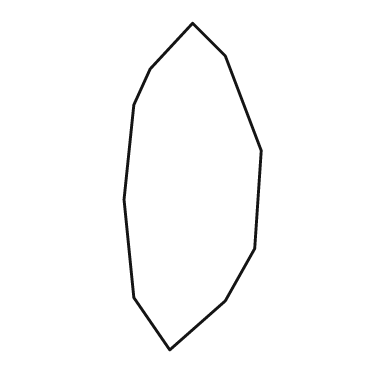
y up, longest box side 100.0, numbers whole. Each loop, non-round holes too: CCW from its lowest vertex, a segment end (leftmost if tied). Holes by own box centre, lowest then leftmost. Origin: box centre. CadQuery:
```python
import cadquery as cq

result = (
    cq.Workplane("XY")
    .moveTo(-7.0, -50.0)
    .lineTo(10.0, -35.0)
    .lineTo(19.0, -19.0)
    .lineTo(21.0, 11.0)
    .lineTo(10.0, 40.0)
    .lineTo(0.0, 50.0)
    .lineTo(-13.0, 36.0)
    .lineTo(-18.0, 25.0)
    .lineTo(-21.0, -4.0)
    .lineTo(-18.0, -34.0)
    .close()
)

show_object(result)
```